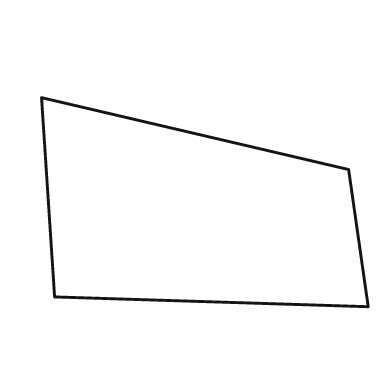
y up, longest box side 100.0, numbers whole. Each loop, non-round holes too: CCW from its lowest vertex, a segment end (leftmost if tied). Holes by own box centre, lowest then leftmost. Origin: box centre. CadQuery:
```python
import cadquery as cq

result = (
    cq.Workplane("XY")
    .moveTo(50.0, -32.0)
    .lineTo(44.0, 10.0)
    .lineTo(-50.0, 32.0)
    .lineTo(-46.0, -29.0)
    .close()
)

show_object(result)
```